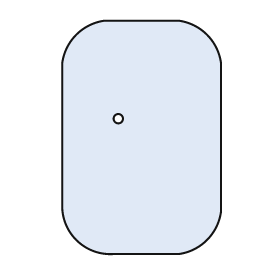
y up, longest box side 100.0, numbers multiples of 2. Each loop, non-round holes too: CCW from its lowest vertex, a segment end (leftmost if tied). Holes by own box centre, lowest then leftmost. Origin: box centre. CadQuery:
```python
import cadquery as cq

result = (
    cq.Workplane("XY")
    .moveTo(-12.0, -50.0)
    .lineTo(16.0, -50.0)
    .threePointArc((28.0, -44.0), (34.0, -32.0))
    .lineTo(34.0, 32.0)
    .threePointArc((28.0, 44.0), (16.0, 50.0))
    .lineTo(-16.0, 50.0)
    .threePointArc((-28.0, 44.0), (-34.0, 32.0))
    .lineTo(-34.0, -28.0)
    .threePointArc((-28.0, -44.0), (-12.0, -50.0))
    .close()
    .moveTo(-10.0, 8.0)
    .circle(2.0)
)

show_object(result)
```